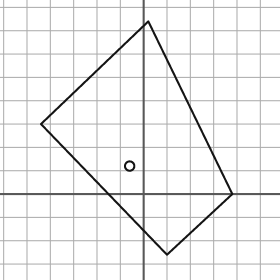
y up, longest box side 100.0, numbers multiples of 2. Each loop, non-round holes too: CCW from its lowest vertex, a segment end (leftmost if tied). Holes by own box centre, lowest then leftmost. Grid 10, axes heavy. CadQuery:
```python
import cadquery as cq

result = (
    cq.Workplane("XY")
    .moveTo(10.0, -26.0)
    .lineTo(38.0, 0.0)
    .lineTo(2.0, 74.0)
    .lineTo(-44.0, 30.0)
    .close()
    .moveTo(-6.0, 12.0)
    .circle(2.0)
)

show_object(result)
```